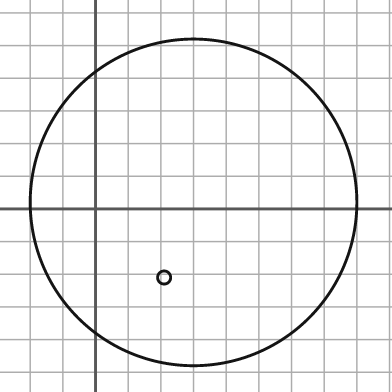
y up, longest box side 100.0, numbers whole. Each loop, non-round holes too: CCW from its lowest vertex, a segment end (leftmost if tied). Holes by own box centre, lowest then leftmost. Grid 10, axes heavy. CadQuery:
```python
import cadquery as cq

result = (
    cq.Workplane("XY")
    .moveTo(30.0, 2.0)
    .circle(50.0)
    .moveTo(21.0, -21.0)
    .circle(2.0)
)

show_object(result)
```